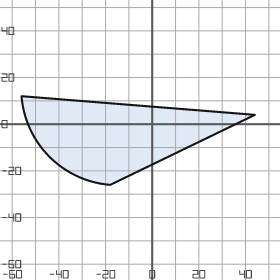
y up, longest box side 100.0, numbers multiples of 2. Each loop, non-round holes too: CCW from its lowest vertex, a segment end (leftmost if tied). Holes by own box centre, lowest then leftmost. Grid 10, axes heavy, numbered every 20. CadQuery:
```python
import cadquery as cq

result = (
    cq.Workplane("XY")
    .moveTo(-18.0, -26.0)
    .lineTo(44.0, 4.0)
    .lineTo(-56.0, 12.0)
    .threePointArc((-44.0, -14.0), (-18.0, -26.0))
    .close()
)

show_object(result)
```